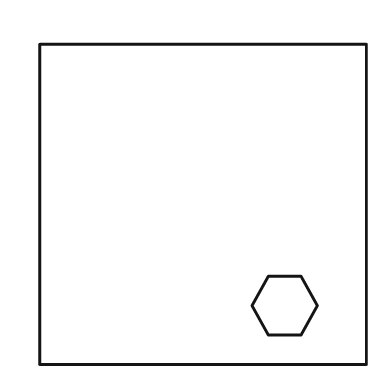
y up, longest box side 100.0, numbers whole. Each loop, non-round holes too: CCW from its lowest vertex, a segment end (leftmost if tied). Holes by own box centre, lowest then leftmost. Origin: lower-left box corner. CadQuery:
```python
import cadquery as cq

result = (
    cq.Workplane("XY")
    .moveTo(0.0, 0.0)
    .lineTo(100.0, 0.0)
    .lineTo(100.0, 98.0)
    .lineTo(0.0, 98.0)
    .close()
    .moveTo(70.0, 9.0)
    .lineTo(80.0, 9.0)
    .lineTo(85.0, 18.0)
    .lineTo(80.0, 27.0)
    .lineTo(70.0, 27.0)
    .lineTo(65.0, 18.0)
    .close()
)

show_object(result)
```